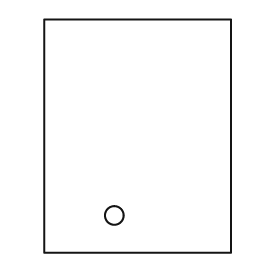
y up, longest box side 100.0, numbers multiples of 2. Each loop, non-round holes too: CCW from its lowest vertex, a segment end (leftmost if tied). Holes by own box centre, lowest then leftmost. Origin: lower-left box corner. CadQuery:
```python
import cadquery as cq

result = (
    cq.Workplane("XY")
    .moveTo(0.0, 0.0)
    .lineTo(80.0, 0.0)
    .lineTo(80.0, 100.0)
    .lineTo(0.0, 100.0)
    .close()
    .moveTo(30.0, 16.0)
    .circle(4.0)
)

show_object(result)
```